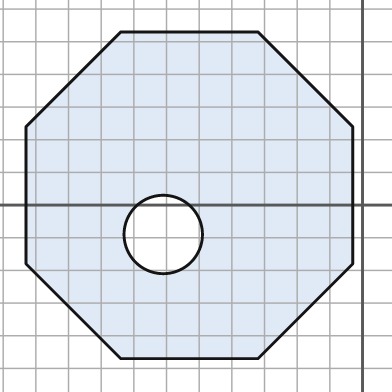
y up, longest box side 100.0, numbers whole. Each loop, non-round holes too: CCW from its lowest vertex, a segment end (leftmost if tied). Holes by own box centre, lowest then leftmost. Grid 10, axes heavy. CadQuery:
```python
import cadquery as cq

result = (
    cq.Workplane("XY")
    .moveTo(-74.0, -47.0)
    .lineTo(-32.0, -47.0)
    .lineTo(-3.0, -18.0)
    .lineTo(-3.0, 24.0)
    .lineTo(-32.0, 53.0)
    .lineTo(-74.0, 53.0)
    .lineTo(-103.0, 24.0)
    .lineTo(-103.0, -18.0)
    .close()
    .moveTo(-61.0, -9.0)
    .circle(12.0)
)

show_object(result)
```